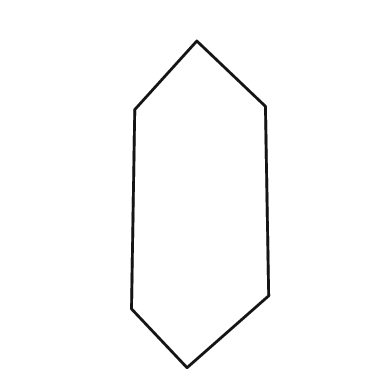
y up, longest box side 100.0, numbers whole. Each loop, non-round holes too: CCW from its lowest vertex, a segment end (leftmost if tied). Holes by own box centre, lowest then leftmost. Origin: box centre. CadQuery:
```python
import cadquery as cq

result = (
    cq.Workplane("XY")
    .moveTo(-4.0, -50.0)
    .lineTo(21.0, -28.0)
    .lineTo(20.0, 30.0)
    .lineTo(-1.0, 50.0)
    .lineTo(-20.0, 29.0)
    .lineTo(-21.0, -32.0)
    .close()
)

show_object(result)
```